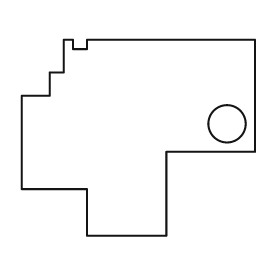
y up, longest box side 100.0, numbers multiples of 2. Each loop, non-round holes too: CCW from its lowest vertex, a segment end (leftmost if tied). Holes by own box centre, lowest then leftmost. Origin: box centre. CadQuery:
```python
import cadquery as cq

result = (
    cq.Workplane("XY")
    .moveTo(-22.0, -42.0)
    .lineTo(12.0, -42.0)
    .lineTo(12.0, -6.0)
    .lineTo(50.0, -6.0)
    .lineTo(50.0, 42.0)
    .lineTo(-22.0, 42.0)
    .lineTo(-22.0, 38.0)
    .lineTo(-28.0, 38.0)
    .lineTo(-28.0, 42.0)
    .lineTo(-32.0, 42.0)
    .lineTo(-32.0, 28.0)
    .lineTo(-38.0, 28.0)
    .lineTo(-38.0, 18.0)
    .lineTo(-50.0, 18.0)
    .lineTo(-50.0, -22.0)
    .lineTo(-22.0, -22.0)
    .close()
    .moveTo(38.0, 6.0)
    .circle(8.0)
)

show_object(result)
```